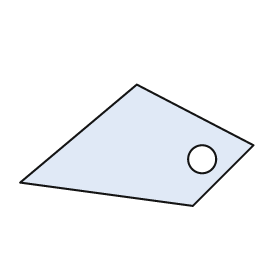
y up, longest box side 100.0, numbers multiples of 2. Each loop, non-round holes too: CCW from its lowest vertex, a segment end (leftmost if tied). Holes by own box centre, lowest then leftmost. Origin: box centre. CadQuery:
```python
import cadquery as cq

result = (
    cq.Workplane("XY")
    .moveTo(24.0, -26.0)
    .lineTo(50.0, 0.0)
    .lineTo(0.0, 26.0)
    .lineTo(-50.0, -16.0)
    .close()
    .moveTo(28.0, -6.0)
    .circle(6.0)
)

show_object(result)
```